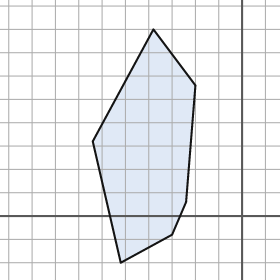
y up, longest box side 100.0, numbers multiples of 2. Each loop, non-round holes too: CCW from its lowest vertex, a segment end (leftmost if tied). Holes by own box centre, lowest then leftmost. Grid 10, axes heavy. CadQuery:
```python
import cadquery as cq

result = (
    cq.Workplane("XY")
    .moveTo(-52.0, -20.0)
    .lineTo(-30.0, -8.0)
    .lineTo(-24.0, 6.0)
    .lineTo(-20.0, 56.0)
    .lineTo(-38.0, 80.0)
    .lineTo(-64.0, 32.0)
    .close()
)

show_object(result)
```